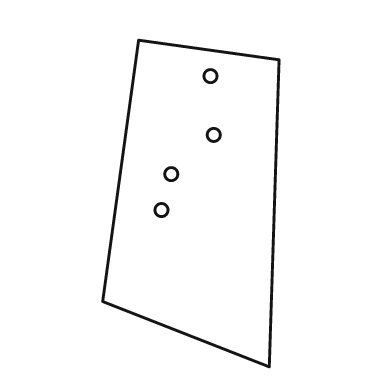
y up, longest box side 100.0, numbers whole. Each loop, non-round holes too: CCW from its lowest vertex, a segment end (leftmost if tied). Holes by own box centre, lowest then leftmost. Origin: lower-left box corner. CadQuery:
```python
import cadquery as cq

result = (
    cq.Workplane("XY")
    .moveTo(51.0, 0.0)
    .lineTo(54.0, 94.0)
    .lineTo(11.0, 100.0)
    .lineTo(0.0, 20.0)
    .close()
    .moveTo(18.0, 48.0)
    .circle(2.0)
    .moveTo(21.0, 59.0)
    .circle(2.0)
    .moveTo(34.0, 71.0)
    .circle(2.0)
    .moveTo(33.0, 89.0)
    .circle(2.0)
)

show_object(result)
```